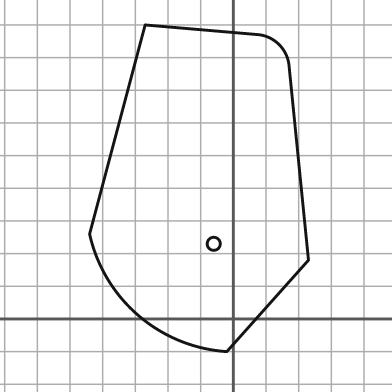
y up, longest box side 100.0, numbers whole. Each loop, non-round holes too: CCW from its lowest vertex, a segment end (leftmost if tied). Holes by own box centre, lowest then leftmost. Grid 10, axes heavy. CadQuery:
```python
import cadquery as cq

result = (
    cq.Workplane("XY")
    .moveTo(-2.0, -10.0)
    .lineTo(23.0, 18.0)
    .lineTo(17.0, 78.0)
    .threePointArc((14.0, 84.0), (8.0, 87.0))
    .lineTo(-27.0, 90.0)
    .lineTo(-44.0, 26.0)
    .threePointArc((-29.0, 1.0), (-2.0, -10.0))
    .close()
    .moveTo(-6.0, 23.0)
    .circle(2.0)
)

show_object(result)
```